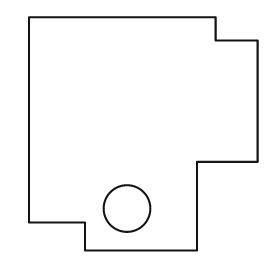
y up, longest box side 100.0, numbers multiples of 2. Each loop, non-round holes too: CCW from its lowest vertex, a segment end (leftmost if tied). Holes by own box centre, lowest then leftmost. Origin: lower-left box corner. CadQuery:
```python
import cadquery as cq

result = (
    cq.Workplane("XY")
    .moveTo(24.0, 0.0)
    .lineTo(72.0, 0.0)
    .lineTo(72.0, 38.0)
    .lineTo(98.0, 38.0)
    .lineTo(98.0, 90.0)
    .lineTo(80.0, 90.0)
    .lineTo(80.0, 100.0)
    .lineTo(0.0, 100.0)
    .lineTo(0.0, 12.0)
    .lineTo(24.0, 12.0)
    .close()
    .moveTo(42.0, 18.0)
    .circle(10.0)
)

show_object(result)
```